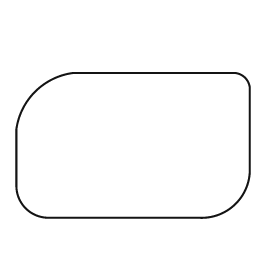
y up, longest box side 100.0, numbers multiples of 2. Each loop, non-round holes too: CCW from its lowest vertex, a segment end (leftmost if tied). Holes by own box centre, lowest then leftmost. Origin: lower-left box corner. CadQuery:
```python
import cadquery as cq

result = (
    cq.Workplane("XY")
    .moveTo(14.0, 0.0)
    .lineTo(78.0, 0.0)
    .threePointArc((94.0, 6.0), (100.0, 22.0))
    .lineTo(100.0, 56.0)
    .threePointArc((98.0, 60.0), (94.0, 62.0))
    .lineTo(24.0, 62.0)
    .threePointArc((8.0, 54.0), (0.0, 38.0))
    .lineTo(0.0, 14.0)
    .threePointArc((4.0, 4.0), (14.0, 0.0))
    .close()
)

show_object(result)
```